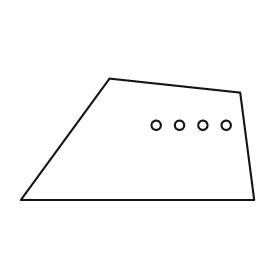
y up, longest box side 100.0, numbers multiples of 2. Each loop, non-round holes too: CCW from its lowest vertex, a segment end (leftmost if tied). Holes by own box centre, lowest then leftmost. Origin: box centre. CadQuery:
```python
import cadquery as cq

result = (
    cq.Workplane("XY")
    .moveTo(-50.0, -26.0)
    .lineTo(50.0, -26.0)
    .lineTo(44.0, 20.0)
    .lineTo(-12.0, 26.0)
    .close()
    .moveTo(8.0, 6.0)
    .circle(2.0)
    .moveTo(18.0, 6.0)
    .circle(2.0)
    .moveTo(28.0, 6.0)
    .circle(2.0)
    .moveTo(38.0, 6.0)
    .circle(2.0)
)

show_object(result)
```